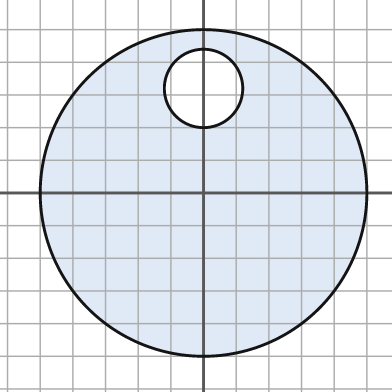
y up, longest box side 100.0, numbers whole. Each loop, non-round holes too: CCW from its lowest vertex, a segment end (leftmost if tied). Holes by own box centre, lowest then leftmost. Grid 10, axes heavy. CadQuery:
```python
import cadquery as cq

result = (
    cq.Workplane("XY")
    .moveTo(0.0, 0.0)
    .circle(50.0)
    .moveTo(0.0, 32.0)
    .circle(12.0)
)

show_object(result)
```